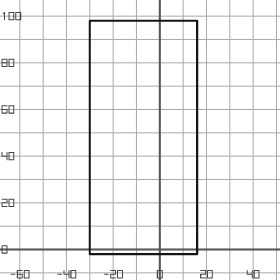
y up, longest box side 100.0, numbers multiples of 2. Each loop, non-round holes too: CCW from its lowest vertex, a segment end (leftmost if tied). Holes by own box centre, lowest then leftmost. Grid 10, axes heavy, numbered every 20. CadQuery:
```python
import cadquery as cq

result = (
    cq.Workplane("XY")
    .moveTo(-30.0, -2.0)
    .lineTo(16.0, -2.0)
    .lineTo(16.0, 98.0)
    .lineTo(-30.0, 98.0)
    .close()
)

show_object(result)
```